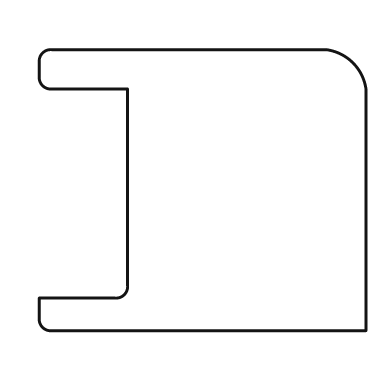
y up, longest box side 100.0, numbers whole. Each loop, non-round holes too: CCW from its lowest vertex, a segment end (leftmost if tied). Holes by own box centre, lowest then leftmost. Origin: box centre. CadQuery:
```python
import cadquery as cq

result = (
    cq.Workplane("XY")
    .moveTo(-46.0, -43.0)
    .lineTo(50.0, -43.0)
    .lineTo(50.0, 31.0)
    .threePointArc((46.0, 39.0), (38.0, 43.0))
    .lineTo(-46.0, 43.0)
    .threePointArc((-49.0, 42.0), (-50.0, 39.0))
    .lineTo(-50.0, 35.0)
    .threePointArc((-49.0, 32.0), (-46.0, 31.0))
    .lineTo(-23.0, 31.0)
    .lineTo(-23.0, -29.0)
    .threePointArc((-24.0, -32.0), (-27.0, -33.0))
    .lineTo(-50.0, -33.0)
    .lineTo(-50.0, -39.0)
    .threePointArc((-49.0, -42.0), (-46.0, -43.0))
    .close()
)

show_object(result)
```